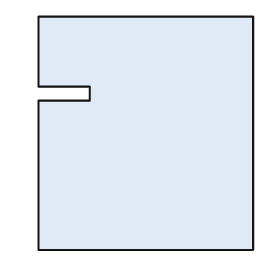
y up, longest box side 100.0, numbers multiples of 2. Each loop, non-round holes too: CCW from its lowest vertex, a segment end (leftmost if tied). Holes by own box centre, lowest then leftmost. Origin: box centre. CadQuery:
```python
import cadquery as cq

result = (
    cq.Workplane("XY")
    .moveTo(-46.0, -50.0)
    .lineTo(46.0, -50.0)
    .lineTo(46.0, 50.0)
    .lineTo(-46.0, 50.0)
    .lineTo(-46.0, 20.0)
    .lineTo(-24.0, 20.0)
    .lineTo(-24.0, 14.0)
    .lineTo(-46.0, 14.0)
    .close()
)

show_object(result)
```